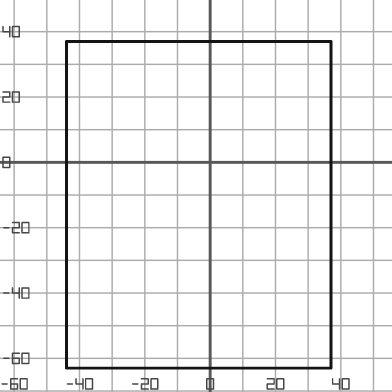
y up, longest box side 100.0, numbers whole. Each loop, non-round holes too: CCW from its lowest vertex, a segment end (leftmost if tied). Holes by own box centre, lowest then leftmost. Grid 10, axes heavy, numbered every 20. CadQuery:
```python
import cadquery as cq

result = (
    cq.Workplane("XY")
    .moveTo(-44.0, -63.0)
    .lineTo(37.0, -63.0)
    .lineTo(37.0, 37.0)
    .lineTo(-44.0, 37.0)
    .close()
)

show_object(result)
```